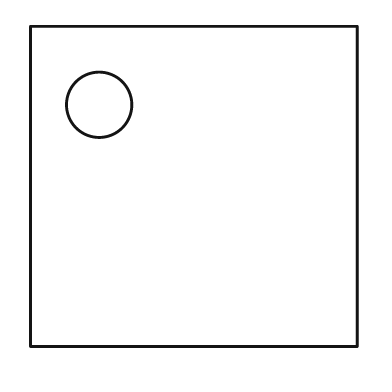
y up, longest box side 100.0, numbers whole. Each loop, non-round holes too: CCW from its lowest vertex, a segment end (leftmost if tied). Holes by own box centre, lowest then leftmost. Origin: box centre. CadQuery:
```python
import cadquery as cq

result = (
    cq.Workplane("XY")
    .moveTo(-50.0, -49.0)
    .lineTo(50.0, -49.0)
    .lineTo(50.0, 49.0)
    .lineTo(-50.0, 49.0)
    .close()
    .moveTo(-29.0, 25.0)
    .circle(10.0)
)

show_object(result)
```